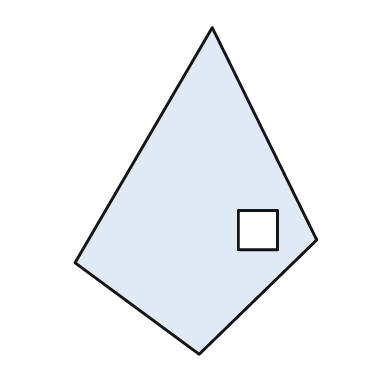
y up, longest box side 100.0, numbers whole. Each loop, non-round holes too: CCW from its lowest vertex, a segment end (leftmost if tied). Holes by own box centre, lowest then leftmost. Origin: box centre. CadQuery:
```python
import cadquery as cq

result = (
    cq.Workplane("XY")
    .moveTo(1.0, -50.0)
    .lineTo(37.0, -15.0)
    .lineTo(5.0, 50.0)
    .lineTo(-37.0, -22.0)
    .close()
    .moveTo(13.0, -18.0)
    .lineTo(25.0, -18.0)
    .lineTo(25.0, -6.0)
    .lineTo(13.0, -6.0)
    .close()
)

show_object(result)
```